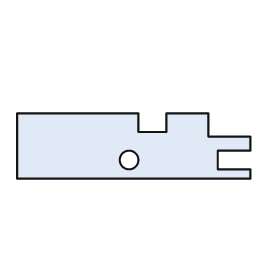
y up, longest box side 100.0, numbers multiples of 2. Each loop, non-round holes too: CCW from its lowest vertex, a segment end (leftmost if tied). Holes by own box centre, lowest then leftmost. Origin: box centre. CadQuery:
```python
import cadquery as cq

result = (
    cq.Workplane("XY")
    .moveTo(-50.0, -14.0)
    .lineTo(50.0, -14.0)
    .lineTo(50.0, -10.0)
    .lineTo(36.0, -10.0)
    .lineTo(36.0, -2.0)
    .lineTo(50.0, -2.0)
    .lineTo(50.0, 4.0)
    .lineTo(32.0, 4.0)
    .lineTo(32.0, 14.0)
    .lineTo(14.0, 14.0)
    .lineTo(14.0, 6.0)
    .lineTo(2.0, 6.0)
    .lineTo(2.0, 14.0)
    .lineTo(-50.0, 14.0)
    .close()
    .moveTo(-2.0, -6.0)
    .circle(4.0)
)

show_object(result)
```